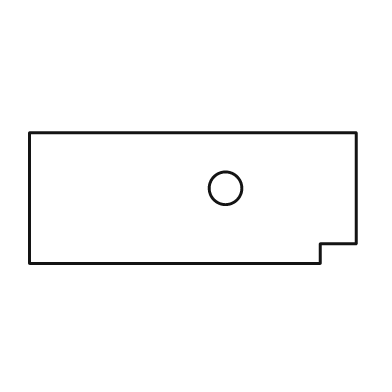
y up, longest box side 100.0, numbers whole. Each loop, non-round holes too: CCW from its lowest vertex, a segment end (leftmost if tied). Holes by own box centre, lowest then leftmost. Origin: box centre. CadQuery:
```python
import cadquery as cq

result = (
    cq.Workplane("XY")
    .moveTo(-50.0, -20.0)
    .lineTo(39.0, -20.0)
    .lineTo(39.0, -14.0)
    .lineTo(50.0, -14.0)
    .lineTo(50.0, 20.0)
    .lineTo(-50.0, 20.0)
    .close()
    .moveTo(10.0, 3.0)
    .circle(5.0)
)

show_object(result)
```